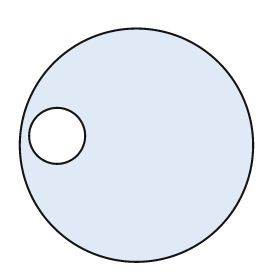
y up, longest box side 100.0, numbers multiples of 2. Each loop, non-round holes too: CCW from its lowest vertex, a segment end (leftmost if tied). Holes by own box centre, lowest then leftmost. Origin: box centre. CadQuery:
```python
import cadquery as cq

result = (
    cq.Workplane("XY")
    .moveTo(0.0, 0.0)
    .circle(50.0)
    .moveTo(-34.0, 4.0)
    .circle(12.0)
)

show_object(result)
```